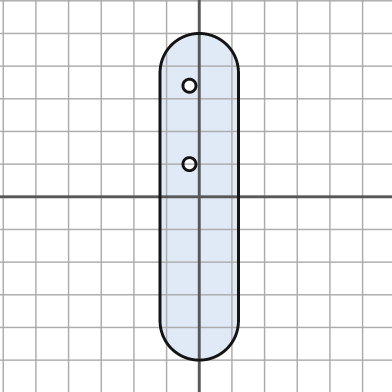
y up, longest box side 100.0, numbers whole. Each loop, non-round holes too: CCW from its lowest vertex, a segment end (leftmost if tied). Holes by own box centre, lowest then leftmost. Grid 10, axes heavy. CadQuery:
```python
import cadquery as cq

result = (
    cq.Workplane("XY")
    .moveTo(-12.0, -38.0)
    .threePointArc((0.0, -50.0), (12.0, -38.0))
    .lineTo(12.0, 38.0)
    .threePointArc((0.0, 50.0), (-12.0, 38.0))
    .close()
    .moveTo(-3.0, 10.0)
    .circle(2.0)
    .moveTo(-3.0, 34.0)
    .circle(2.0)
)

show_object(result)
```